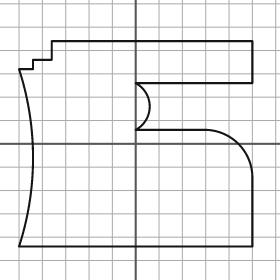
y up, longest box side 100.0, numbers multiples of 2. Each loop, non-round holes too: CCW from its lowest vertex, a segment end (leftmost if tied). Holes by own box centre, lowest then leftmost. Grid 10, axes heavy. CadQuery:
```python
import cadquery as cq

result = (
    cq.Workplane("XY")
    .moveTo(-50.0, -44.0)
    .lineTo(50.0, -44.0)
    .lineTo(50.0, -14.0)
    .threePointArc((44.0, 0.0), (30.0, 6.0))
    .lineTo(0.0, 6.0)
    .threePointArc((6.0, 16.0), (0.0, 26.0))
    .lineTo(50.0, 26.0)
    .lineTo(50.0, 44.0)
    .lineTo(-36.0, 44.0)
    .lineTo(-36.0, 36.0)
    .lineTo(-44.0, 36.0)
    .lineTo(-44.0, 32.0)
    .lineTo(-50.0, 32.0)
    .threePointArc((-44.0, -6.0), (-50.0, -44.0))
    .close()
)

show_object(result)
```